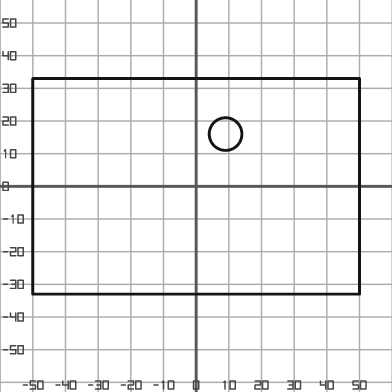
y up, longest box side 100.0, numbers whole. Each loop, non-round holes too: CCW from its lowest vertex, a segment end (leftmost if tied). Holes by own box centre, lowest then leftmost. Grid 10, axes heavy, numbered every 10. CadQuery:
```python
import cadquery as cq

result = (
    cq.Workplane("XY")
    .moveTo(-50.0, -33.0)
    .lineTo(50.0, -33.0)
    .lineTo(50.0, 33.0)
    .lineTo(-50.0, 33.0)
    .close()
    .moveTo(9.0, 16.0)
    .circle(5.0)
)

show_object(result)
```